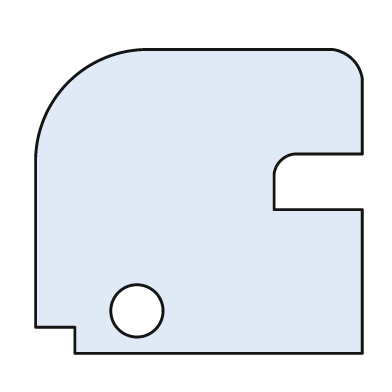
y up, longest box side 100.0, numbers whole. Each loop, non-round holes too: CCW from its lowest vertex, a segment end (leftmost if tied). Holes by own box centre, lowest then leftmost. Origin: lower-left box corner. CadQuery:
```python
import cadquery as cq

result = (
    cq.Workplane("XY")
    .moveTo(12.0, 0.0)
    .lineTo(100.0, 0.0)
    .lineTo(100.0, 44.0)
    .lineTo(73.0, 44.0)
    .lineTo(73.0, 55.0)
    .threePointArc((75.0, 59.0), (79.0, 61.0))
    .lineTo(100.0, 61.0)
    .lineTo(100.0, 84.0)
    .threePointArc((97.0, 90.0), (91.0, 93.0))
    .lineTo(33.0, 93.0)
    .threePointArc((10.0, 83.0), (0.0, 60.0))
    .lineTo(0.0, 8.0)
    .lineTo(12.0, 8.0)
    .close()
    .moveTo(31.0, 13.0)
    .circle(8.0)
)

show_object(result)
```